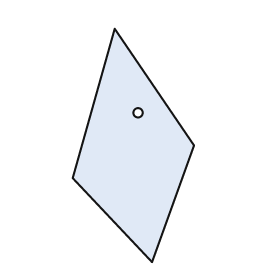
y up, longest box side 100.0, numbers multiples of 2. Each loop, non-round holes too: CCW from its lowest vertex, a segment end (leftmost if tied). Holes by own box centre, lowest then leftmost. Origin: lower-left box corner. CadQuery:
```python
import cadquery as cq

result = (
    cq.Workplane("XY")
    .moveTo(34.0, 0.0)
    .lineTo(52.0, 50.0)
    .lineTo(18.0, 100.0)
    .lineTo(0.0, 36.0)
    .close()
    .moveTo(28.0, 64.0)
    .circle(2.0)
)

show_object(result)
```